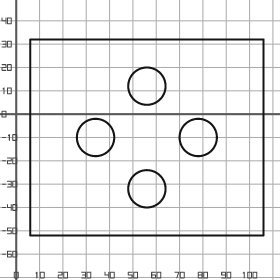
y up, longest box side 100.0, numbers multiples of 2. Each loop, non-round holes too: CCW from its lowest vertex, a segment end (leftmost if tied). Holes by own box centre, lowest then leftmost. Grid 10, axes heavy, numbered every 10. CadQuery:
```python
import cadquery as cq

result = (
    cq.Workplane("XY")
    .moveTo(6.0, -52.0)
    .lineTo(106.0, -52.0)
    .lineTo(106.0, 32.0)
    .lineTo(6.0, 32.0)
    .close()
    .moveTo(56.0, -32.0)
    .circle(8.0)
    .moveTo(34.0, -10.0)
    .circle(8.0)
    .moveTo(78.0, -10.0)
    .circle(8.0)
    .moveTo(56.0, 12.0)
    .circle(8.0)
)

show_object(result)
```